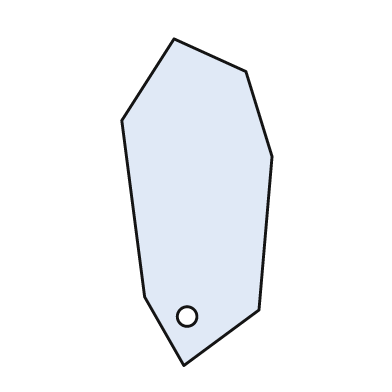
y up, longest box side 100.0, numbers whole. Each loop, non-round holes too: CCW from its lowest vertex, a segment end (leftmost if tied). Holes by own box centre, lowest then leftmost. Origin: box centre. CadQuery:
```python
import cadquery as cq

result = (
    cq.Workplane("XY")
    .moveTo(-4.0, -50.0)
    .lineTo(19.0, -33.0)
    .lineTo(23.0, 14.0)
    .lineTo(15.0, 40.0)
    .lineTo(-7.0, 50.0)
    .lineTo(-23.0, 25.0)
    .lineTo(-16.0, -29.0)
    .close()
    .moveTo(-3.0, -35.0)
    .circle(3.0)
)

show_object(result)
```